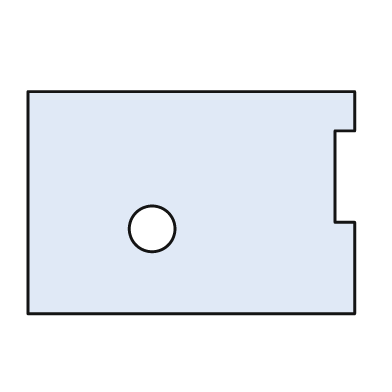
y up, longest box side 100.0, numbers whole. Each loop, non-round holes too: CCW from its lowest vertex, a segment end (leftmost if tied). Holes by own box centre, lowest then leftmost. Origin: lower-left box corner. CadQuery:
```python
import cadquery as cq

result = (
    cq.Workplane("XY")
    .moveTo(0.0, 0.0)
    .lineTo(100.0, 0.0)
    .lineTo(100.0, 28.0)
    .lineTo(94.0, 28.0)
    .lineTo(94.0, 56.0)
    .lineTo(100.0, 56.0)
    .lineTo(100.0, 68.0)
    .lineTo(0.0, 68.0)
    .close()
    .moveTo(38.0, 26.0)
    .circle(7.0)
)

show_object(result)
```